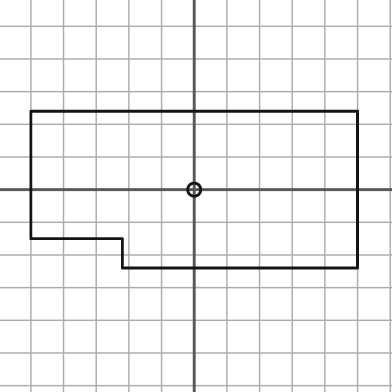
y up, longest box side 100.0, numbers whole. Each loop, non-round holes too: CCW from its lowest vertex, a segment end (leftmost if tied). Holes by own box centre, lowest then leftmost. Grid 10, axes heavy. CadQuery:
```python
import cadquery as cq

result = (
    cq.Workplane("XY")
    .moveTo(-22.0, -24.0)
    .lineTo(50.0, -24.0)
    .lineTo(50.0, 24.0)
    .lineTo(-50.0, 24.0)
    .lineTo(-50.0, -15.0)
    .lineTo(-22.0, -15.0)
    .close()
    .moveTo(0.0, 0.0)
    .circle(2.0)
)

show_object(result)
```